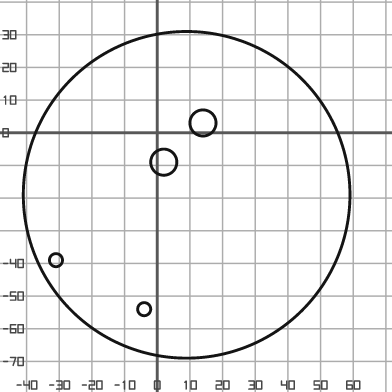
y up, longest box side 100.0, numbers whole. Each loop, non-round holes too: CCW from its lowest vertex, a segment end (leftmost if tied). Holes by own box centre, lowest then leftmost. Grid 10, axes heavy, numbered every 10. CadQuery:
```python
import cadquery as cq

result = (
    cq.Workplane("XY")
    .moveTo(9.0, -19.0)
    .circle(50.0)
    .moveTo(-4.0, -54.0)
    .circle(2.0)
    .moveTo(-31.0, -39.0)
    .circle(2.0)
    .moveTo(2.0, -9.0)
    .circle(4.0)
    .moveTo(14.0, 3.0)
    .circle(4.0)
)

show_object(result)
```